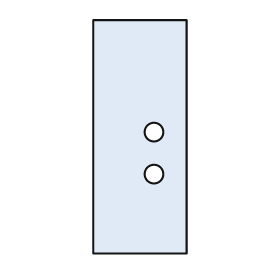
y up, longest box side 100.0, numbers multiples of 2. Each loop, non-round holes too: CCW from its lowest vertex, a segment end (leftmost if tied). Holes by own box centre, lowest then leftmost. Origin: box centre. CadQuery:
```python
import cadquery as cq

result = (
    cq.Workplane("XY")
    .moveTo(-20.0, -50.0)
    .lineTo(20.0, -50.0)
    .lineTo(20.0, 50.0)
    .lineTo(-20.0, 50.0)
    .close()
    .moveTo(6.0, -16.0)
    .circle(4.0)
    .moveTo(6.0, 2.0)
    .circle(4.0)
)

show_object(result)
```